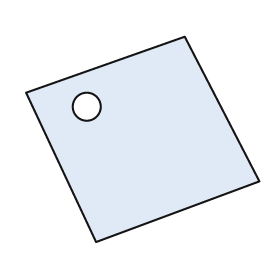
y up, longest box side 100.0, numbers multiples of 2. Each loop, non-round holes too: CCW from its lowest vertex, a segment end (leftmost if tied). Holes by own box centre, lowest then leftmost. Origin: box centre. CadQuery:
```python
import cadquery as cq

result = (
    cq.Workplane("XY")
    .moveTo(-20.0, -44.0)
    .lineTo(50.0, -18.0)
    .lineTo(18.0, 44.0)
    .lineTo(-50.0, 20.0)
    .close()
    .moveTo(-24.0, 14.0)
    .circle(6.0)
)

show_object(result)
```